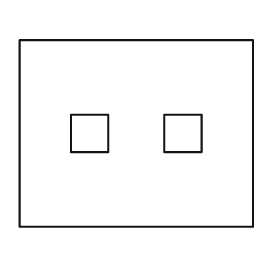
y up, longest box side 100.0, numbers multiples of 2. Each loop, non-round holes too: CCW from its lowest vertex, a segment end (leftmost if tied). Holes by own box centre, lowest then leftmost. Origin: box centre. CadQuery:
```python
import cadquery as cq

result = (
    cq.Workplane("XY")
    .moveTo(-50.0, -40.0)
    .lineTo(50.0, -40.0)
    .lineTo(50.0, 40.0)
    .lineTo(-50.0, 40.0)
    .close()
    .moveTo(-28.0, -8.0)
    .lineTo(-12.0, -8.0)
    .lineTo(-12.0, 8.0)
    .lineTo(-28.0, 8.0)
    .close()
    .moveTo(12.0, -8.0)
    .lineTo(28.0, -8.0)
    .lineTo(28.0, 8.0)
    .lineTo(12.0, 8.0)
    .close()
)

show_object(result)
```